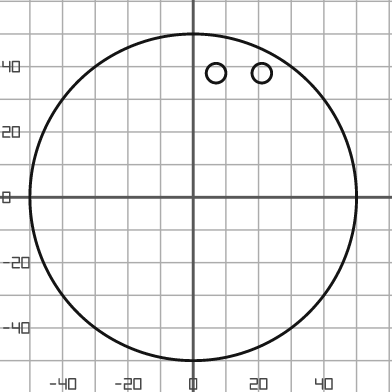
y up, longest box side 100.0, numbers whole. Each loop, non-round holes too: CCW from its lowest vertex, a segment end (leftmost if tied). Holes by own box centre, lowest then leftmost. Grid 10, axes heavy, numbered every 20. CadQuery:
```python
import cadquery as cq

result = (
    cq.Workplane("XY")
    .moveTo(0.0, 0.0)
    .circle(50.0)
    .moveTo(7.0, 38.0)
    .circle(3.0)
    .moveTo(21.0, 38.0)
    .circle(3.0)
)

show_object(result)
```